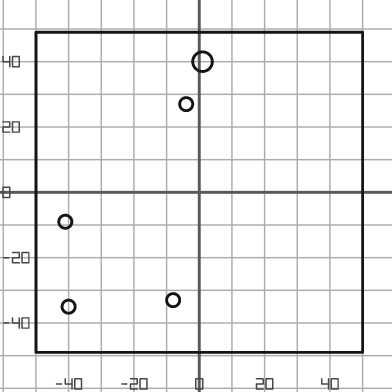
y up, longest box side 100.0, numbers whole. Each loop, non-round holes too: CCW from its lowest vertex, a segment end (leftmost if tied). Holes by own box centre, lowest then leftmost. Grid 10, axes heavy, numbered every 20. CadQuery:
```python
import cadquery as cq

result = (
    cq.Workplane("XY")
    .moveTo(-50.0, -49.0)
    .lineTo(50.0, -49.0)
    .lineTo(50.0, 49.0)
    .lineTo(-50.0, 49.0)
    .close()
    .moveTo(-40.0, -35.0)
    .circle(2.0)
    .moveTo(-8.0, -33.0)
    .circle(2.0)
    .moveTo(-41.0, -9.0)
    .circle(2.0)
    .moveTo(-4.0, 27.0)
    .circle(2.0)
    .moveTo(1.0, 40.0)
    .circle(3.0)
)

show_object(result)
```